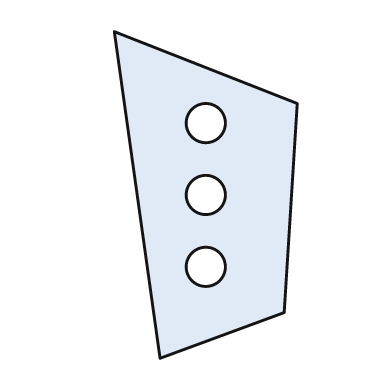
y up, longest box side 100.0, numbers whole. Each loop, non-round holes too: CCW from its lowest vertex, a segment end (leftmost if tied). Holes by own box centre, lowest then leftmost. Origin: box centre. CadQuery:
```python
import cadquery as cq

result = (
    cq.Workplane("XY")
    .moveTo(-14.0, -50.0)
    .lineTo(24.0, -36.0)
    .lineTo(28.0, 28.0)
    .lineTo(-28.0, 50.0)
    .close()
    .moveTo(0.0, -22.0)
    .circle(6.0)
    .moveTo(0.0, 0.0)
    .circle(6.0)
    .moveTo(0.0, 22.0)
    .circle(6.0)
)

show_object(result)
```